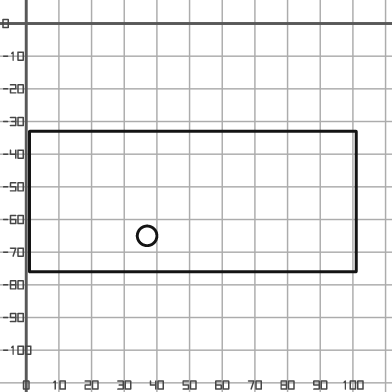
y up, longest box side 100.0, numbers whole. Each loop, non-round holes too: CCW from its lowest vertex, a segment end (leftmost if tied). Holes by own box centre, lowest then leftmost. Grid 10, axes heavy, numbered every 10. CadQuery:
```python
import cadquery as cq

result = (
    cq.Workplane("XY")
    .moveTo(1.0, -76.0)
    .lineTo(101.0, -76.0)
    .lineTo(101.0, -33.0)
    .lineTo(1.0, -33.0)
    .close()
    .moveTo(37.0, -65.0)
    .circle(3.0)
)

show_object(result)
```